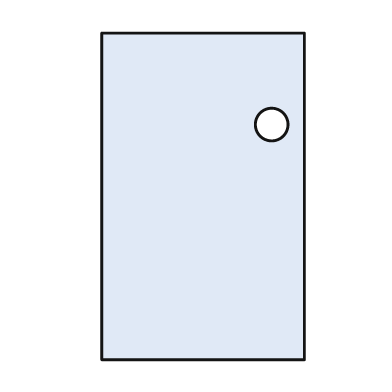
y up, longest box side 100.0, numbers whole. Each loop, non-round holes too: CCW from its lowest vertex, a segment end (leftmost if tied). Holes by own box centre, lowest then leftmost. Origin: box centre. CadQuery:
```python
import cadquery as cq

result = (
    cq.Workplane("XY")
    .moveTo(-31.0, -50.0)
    .lineTo(31.0, -50.0)
    .lineTo(31.0, 50.0)
    .lineTo(-31.0, 50.0)
    .close()
    .moveTo(21.0, 22.0)
    .circle(5.0)
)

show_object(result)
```